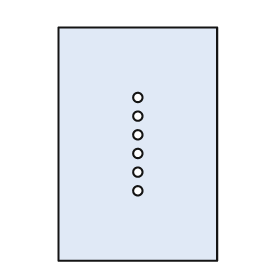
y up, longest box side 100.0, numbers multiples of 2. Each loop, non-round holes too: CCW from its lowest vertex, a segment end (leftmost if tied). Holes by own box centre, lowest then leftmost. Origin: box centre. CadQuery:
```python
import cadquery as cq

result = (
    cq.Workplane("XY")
    .moveTo(-34.0, -50.0)
    .lineTo(34.0, -50.0)
    .lineTo(34.0, 50.0)
    .lineTo(-34.0, 50.0)
    .close()
    .moveTo(0.0, -20.0)
    .circle(2.0)
    .moveTo(0.0, -12.0)
    .circle(2.0)
    .moveTo(0.0, -4.0)
    .circle(2.0)
    .moveTo(0.0, 4.0)
    .circle(2.0)
    .moveTo(0.0, 12.0)
    .circle(2.0)
    .moveTo(0.0, 20.0)
    .circle(2.0)
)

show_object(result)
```